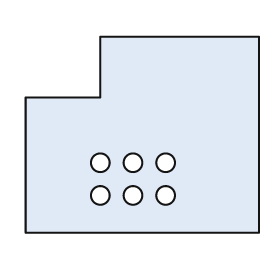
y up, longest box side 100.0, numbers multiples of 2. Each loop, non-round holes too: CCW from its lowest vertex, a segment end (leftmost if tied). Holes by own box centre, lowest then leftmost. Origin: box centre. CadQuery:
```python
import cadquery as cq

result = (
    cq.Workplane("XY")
    .moveTo(-50.0, -42.0)
    .lineTo(50.0, -42.0)
    .lineTo(50.0, 42.0)
    .lineTo(-18.0, 42.0)
    .lineTo(-18.0, 16.0)
    .lineTo(-50.0, 16.0)
    .close()
    .moveTo(-18.0, -26.0)
    .circle(4.0)
    .moveTo(-4.0, -26.0)
    .circle(4.0)
    .moveTo(10.0, -26.0)
    .circle(4.0)
    .moveTo(-18.0, -12.0)
    .circle(4.0)
    .moveTo(-4.0, -12.0)
    .circle(4.0)
    .moveTo(10.0, -12.0)
    .circle(4.0)
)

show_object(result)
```